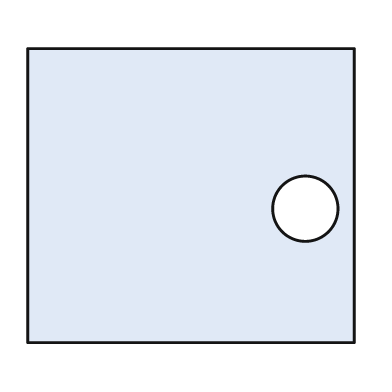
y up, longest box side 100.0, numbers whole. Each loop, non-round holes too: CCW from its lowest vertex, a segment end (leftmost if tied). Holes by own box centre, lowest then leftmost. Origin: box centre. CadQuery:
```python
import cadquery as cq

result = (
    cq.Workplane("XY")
    .moveTo(-50.0, -45.0)
    .lineTo(50.0, -45.0)
    .lineTo(50.0, 45.0)
    .lineTo(-50.0, 45.0)
    .close()
    .moveTo(35.0, -4.0)
    .circle(10.0)
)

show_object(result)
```